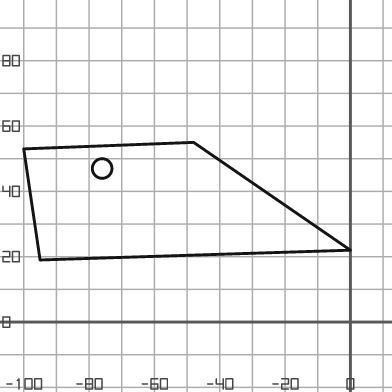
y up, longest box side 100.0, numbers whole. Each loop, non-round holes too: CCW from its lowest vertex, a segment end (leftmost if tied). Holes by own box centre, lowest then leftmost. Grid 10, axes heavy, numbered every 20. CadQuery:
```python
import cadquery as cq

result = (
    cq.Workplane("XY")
    .moveTo(-95.0, 19.0)
    .lineTo(0.0, 22.0)
    .lineTo(-48.0, 55.0)
    .lineTo(-100.0, 53.0)
    .close()
    .moveTo(-76.0, 47.0)
    .circle(3.0)
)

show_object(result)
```